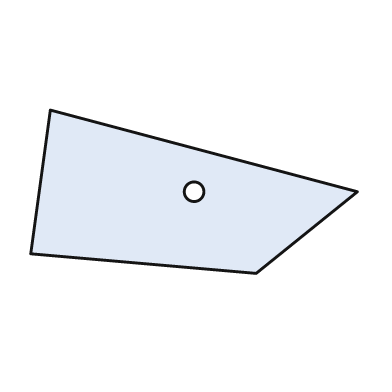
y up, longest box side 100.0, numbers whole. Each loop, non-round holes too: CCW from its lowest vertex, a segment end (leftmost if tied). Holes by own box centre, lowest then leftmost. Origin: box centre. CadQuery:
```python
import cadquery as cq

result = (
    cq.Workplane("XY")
    .moveTo(19.0, -25.0)
    .lineTo(50.0, 0.0)
    .lineTo(-44.0, 25.0)
    .lineTo(-50.0, -19.0)
    .close()
    .moveTo(0.0, 0.0)
    .circle(3.0)
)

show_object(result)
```